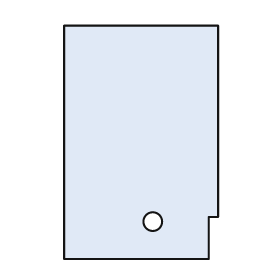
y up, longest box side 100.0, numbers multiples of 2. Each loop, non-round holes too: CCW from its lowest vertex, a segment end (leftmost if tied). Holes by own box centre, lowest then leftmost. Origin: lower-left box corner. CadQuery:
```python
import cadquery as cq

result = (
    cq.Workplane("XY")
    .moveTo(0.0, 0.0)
    .lineTo(62.0, 0.0)
    .lineTo(62.0, 18.0)
    .lineTo(66.0, 18.0)
    .lineTo(66.0, 100.0)
    .lineTo(0.0, 100.0)
    .close()
    .moveTo(38.0, 16.0)
    .circle(4.0)
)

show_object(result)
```